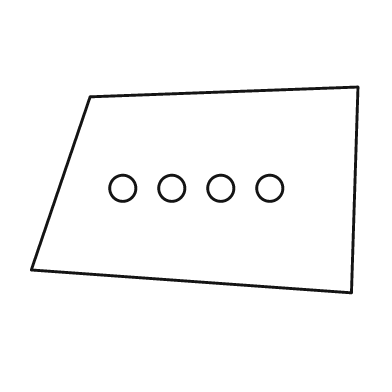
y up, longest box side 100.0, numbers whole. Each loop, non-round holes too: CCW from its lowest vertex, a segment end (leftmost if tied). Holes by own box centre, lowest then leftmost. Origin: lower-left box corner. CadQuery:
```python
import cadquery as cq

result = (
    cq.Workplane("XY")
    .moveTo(98.0, 0.0)
    .lineTo(100.0, 63.0)
    .lineTo(18.0, 60.0)
    .lineTo(0.0, 7.0)
    .close()
    .moveTo(28.0, 32.0)
    .circle(4.0)
    .moveTo(43.0, 32.0)
    .circle(4.0)
    .moveTo(58.0, 32.0)
    .circle(4.0)
    .moveTo(73.0, 32.0)
    .circle(4.0)
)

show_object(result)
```